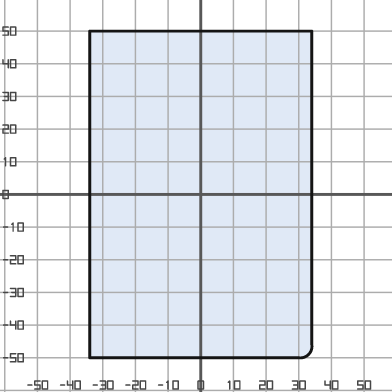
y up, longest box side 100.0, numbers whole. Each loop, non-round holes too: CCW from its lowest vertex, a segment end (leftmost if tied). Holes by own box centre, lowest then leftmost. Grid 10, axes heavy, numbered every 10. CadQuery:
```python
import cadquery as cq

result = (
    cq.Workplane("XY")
    .moveTo(-34.0, -50.0)
    .lineTo(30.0, -50.0)
    .threePointArc((33.0, -49.0), (34.0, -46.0))
    .lineTo(34.0, 50.0)
    .lineTo(-34.0, 50.0)
    .close()
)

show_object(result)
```